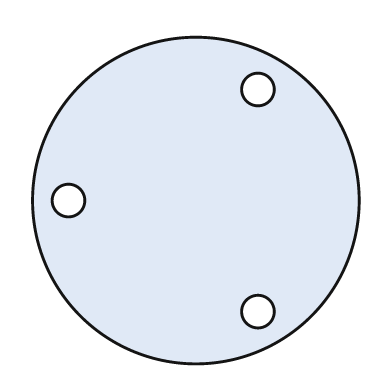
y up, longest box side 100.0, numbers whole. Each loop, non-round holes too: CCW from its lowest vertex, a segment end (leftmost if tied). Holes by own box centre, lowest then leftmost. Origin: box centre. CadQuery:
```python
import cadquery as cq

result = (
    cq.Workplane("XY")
    .moveTo(0.0, 0.0)
    .circle(50.0)
    .moveTo(19.0, -34.0)
    .circle(5.0)
    .moveTo(-39.0, 0.0)
    .circle(5.0)
    .moveTo(19.0, 34.0)
    .circle(5.0)
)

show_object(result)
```